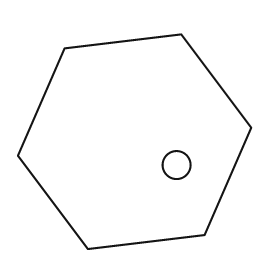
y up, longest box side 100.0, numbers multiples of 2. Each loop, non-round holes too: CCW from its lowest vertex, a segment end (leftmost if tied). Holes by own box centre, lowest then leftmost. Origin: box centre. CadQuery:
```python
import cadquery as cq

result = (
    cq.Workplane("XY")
    .moveTo(-20.0, -46.0)
    .lineTo(30.0, -40.0)
    .lineTo(50.0, 6.0)
    .lineTo(20.0, 46.0)
    .lineTo(-30.0, 40.0)
    .lineTo(-50.0, -6.0)
    .close()
    .moveTo(18.0, -10.0)
    .circle(6.0)
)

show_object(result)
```